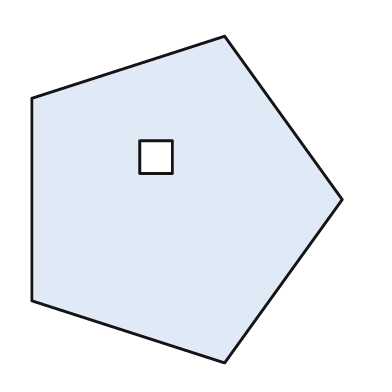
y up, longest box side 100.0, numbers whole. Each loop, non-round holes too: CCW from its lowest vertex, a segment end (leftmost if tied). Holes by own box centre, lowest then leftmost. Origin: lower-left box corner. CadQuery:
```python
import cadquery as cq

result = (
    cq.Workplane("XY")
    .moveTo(59.0, 0.0)
    .lineTo(95.0, 50.0)
    .lineTo(59.0, 100.0)
    .lineTo(0.0, 81.0)
    .lineTo(0.0, 19.0)
    .close()
    .moveTo(33.0, 58.0)
    .lineTo(43.0, 58.0)
    .lineTo(43.0, 68.0)
    .lineTo(33.0, 68.0)
    .close()
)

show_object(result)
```